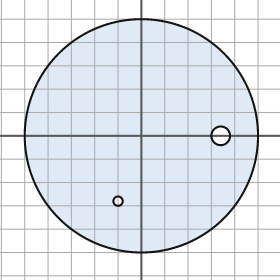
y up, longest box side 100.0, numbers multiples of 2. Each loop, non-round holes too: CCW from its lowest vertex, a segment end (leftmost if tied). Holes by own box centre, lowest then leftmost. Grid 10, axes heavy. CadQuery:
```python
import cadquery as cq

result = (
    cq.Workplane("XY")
    .moveTo(0.0, 0.0)
    .circle(50.0)
    .moveTo(-10.0, -28.0)
    .circle(2.0)
    .moveTo(34.0, 0.0)
    .circle(4.0)
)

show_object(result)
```